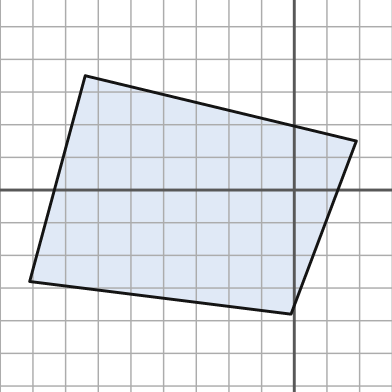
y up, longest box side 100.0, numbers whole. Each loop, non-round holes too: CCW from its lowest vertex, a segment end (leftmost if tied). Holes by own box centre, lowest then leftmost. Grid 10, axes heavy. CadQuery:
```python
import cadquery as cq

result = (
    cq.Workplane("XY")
    .moveTo(-1.0, -38.0)
    .lineTo(19.0, 15.0)
    .lineTo(-64.0, 35.0)
    .lineTo(-81.0, -28.0)
    .close()
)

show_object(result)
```